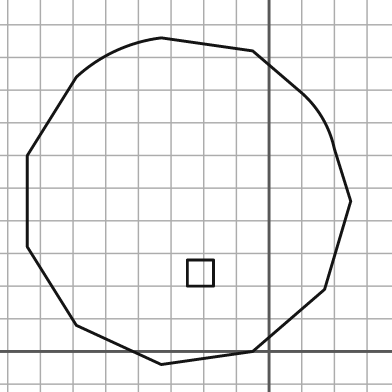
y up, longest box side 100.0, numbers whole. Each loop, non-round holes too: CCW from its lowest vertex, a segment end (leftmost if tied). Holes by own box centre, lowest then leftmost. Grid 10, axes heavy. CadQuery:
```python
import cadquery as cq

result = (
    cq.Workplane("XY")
    .moveTo(-33.0, -4.0)
    .lineTo(-5.0, 0.0)
    .lineTo(17.0, 19.0)
    .lineTo(25.0, 46.0)
    .lineTo(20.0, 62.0)
    .threePointArc((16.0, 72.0), (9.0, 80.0))
    .lineTo(-5.0, 92.0)
    .lineTo(-33.0, 96.0)
    .threePointArc((-47.0, 92.0), (-59.0, 84.0))
    .lineTo(-74.0, 60.0)
    .lineTo(-74.0, 32.0)
    .lineTo(-59.0, 8.0)
    .close()
    .moveTo(-25.0, 20.0)
    .lineTo(-17.0, 20.0)
    .lineTo(-17.0, 28.0)
    .lineTo(-25.0, 28.0)
    .close()
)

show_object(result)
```